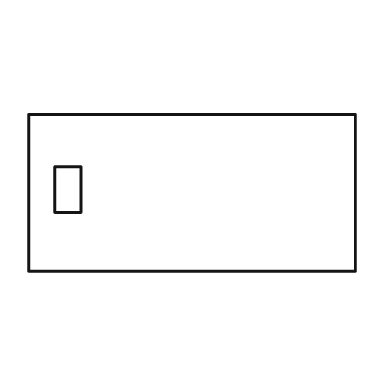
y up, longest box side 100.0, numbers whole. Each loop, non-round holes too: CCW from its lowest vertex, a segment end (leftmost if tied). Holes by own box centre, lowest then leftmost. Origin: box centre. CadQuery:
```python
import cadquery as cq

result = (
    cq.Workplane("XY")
    .moveTo(-50.0, -24.0)
    .lineTo(50.0, -24.0)
    .lineTo(50.0, 24.0)
    .lineTo(-50.0, 24.0)
    .close()
    .moveTo(-42.0, -6.0)
    .lineTo(-34.0, -6.0)
    .lineTo(-34.0, 8.0)
    .lineTo(-42.0, 8.0)
    .close()
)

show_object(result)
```